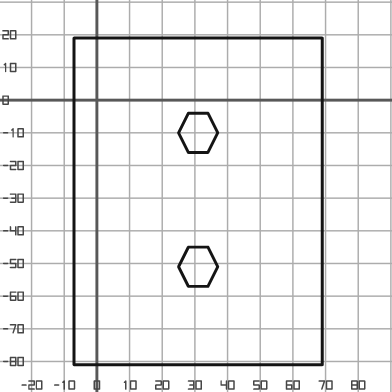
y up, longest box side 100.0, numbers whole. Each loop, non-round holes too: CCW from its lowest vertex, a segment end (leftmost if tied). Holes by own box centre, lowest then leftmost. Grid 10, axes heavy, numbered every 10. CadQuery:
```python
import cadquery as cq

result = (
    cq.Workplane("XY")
    .moveTo(-7.0, -81.0)
    .lineTo(69.0, -81.0)
    .lineTo(69.0, 19.0)
    .lineTo(-7.0, 19.0)
    .close()
    .moveTo(28.0, -57.0)
    .lineTo(34.0, -57.0)
    .lineTo(37.0, -51.0)
    .lineTo(34.0, -45.0)
    .lineTo(28.0, -45.0)
    .lineTo(25.0, -51.0)
    .close()
    .moveTo(28.0, -16.0)
    .lineTo(34.0, -16.0)
    .lineTo(37.0, -10.0)
    .lineTo(34.0, -4.0)
    .lineTo(28.0, -4.0)
    .lineTo(25.0, -10.0)
    .close()
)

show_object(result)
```